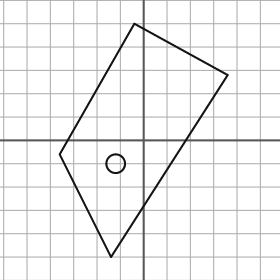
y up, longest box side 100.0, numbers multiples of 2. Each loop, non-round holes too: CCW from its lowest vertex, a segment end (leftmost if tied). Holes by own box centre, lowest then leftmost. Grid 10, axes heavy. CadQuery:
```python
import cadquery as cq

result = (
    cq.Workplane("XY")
    .moveTo(-14.0, -50.0)
    .lineTo(36.0, 28.0)
    .lineTo(-4.0, 50.0)
    .lineTo(-36.0, -6.0)
    .close()
    .moveTo(-12.0, -10.0)
    .circle(4.0)
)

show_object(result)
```